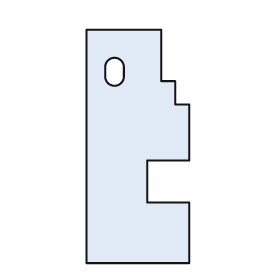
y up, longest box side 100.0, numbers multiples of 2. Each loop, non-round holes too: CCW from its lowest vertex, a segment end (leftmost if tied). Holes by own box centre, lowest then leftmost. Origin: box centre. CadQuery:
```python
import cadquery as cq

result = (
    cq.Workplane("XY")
    .moveTo(-22.0, -50.0)
    .lineTo(22.0, -50.0)
    .lineTo(22.0, -24.0)
    .lineTo(4.0, -24.0)
    .lineTo(4.0, -6.0)
    .lineTo(22.0, -6.0)
    .lineTo(22.0, 18.0)
    .lineTo(16.0, 18.0)
    .lineTo(16.0, 28.0)
    .lineTo(10.0, 28.0)
    .lineTo(10.0, 50.0)
    .lineTo(-22.0, 50.0)
    .close()
    .moveTo(-14.0, 30.0)
    .threePointArc((-10.0, 26.0), (-6.0, 30.0))
    .lineTo(-6.0, 34.0)
    .threePointArc((-10.0, 38.0), (-14.0, 34.0))
    .close()
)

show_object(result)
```